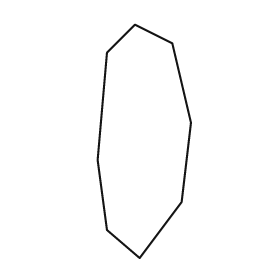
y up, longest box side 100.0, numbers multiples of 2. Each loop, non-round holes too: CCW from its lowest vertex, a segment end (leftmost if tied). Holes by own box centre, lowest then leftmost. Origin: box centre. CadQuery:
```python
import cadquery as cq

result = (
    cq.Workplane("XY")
    .moveTo(-2.0, -50.0)
    .lineTo(16.0, -26.0)
    .lineTo(20.0, 8.0)
    .lineTo(12.0, 42.0)
    .lineTo(-4.0, 50.0)
    .lineTo(-16.0, 38.0)
    .lineTo(-20.0, -8.0)
    .lineTo(-16.0, -38.0)
    .close()
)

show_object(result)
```